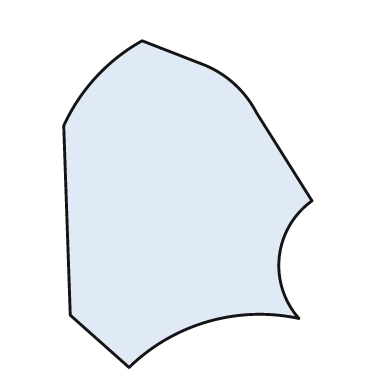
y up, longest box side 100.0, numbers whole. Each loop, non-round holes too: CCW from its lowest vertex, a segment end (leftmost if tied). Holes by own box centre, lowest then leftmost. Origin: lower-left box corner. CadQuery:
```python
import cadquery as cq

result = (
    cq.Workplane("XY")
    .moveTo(20.0, 0.0)
    .threePointArc((44.0, 14.0), (72.0, 15.0))
    .threePointArc((66.0, 34.0), (76.0, 51.0))
    .lineTo(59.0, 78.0)
    .threePointArc((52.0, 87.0), (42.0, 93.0))
    .lineTo(24.0, 100.0)
    .threePointArc((10.0, 89.0), (0.0, 74.0))
    .lineTo(2.0, 16.0)
    .close()
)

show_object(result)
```